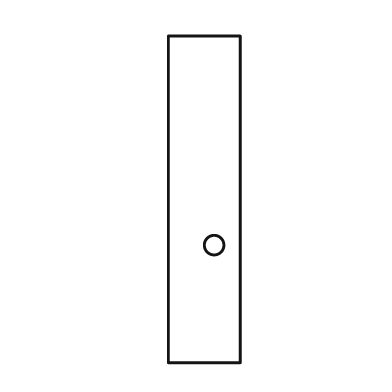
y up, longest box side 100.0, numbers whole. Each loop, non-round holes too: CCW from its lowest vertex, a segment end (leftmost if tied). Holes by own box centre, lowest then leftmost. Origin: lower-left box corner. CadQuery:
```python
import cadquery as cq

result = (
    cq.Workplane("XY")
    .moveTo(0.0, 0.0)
    .lineTo(22.0, 0.0)
    .lineTo(22.0, 100.0)
    .lineTo(0.0, 100.0)
    .close()
    .moveTo(14.0, 36.0)
    .circle(3.0)
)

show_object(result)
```